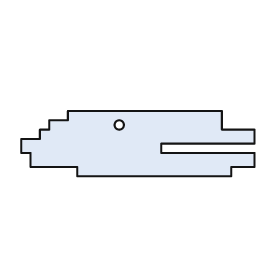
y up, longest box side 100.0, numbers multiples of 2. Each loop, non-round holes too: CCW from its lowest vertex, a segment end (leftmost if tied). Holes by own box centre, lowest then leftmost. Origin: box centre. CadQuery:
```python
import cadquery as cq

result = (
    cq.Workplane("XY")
    .moveTo(-26.0, -14.0)
    .lineTo(40.0, -14.0)
    .lineTo(40.0, -10.0)
    .lineTo(50.0, -10.0)
    .lineTo(50.0, -4.0)
    .lineTo(10.0, -4.0)
    .lineTo(10.0, 0.0)
    .lineTo(50.0, 0.0)
    .lineTo(50.0, 6.0)
    .lineTo(36.0, 6.0)
    .lineTo(36.0, 14.0)
    .lineTo(-30.0, 14.0)
    .lineTo(-30.0, 10.0)
    .lineTo(-38.0, 10.0)
    .lineTo(-38.0, 6.0)
    .lineTo(-42.0, 6.0)
    .lineTo(-42.0, 2.0)
    .lineTo(-50.0, 2.0)
    .lineTo(-50.0, -4.0)
    .lineTo(-46.0, -4.0)
    .lineTo(-46.0, -10.0)
    .lineTo(-26.0, -10.0)
    .close()
    .moveTo(-8.0, 8.0)
    .circle(2.0)
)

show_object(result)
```